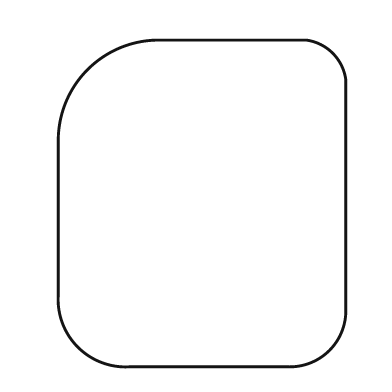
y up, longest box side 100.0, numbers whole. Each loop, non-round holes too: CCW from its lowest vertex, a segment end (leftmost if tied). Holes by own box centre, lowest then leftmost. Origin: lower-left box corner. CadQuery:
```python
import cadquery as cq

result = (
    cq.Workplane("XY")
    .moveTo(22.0, 0.0)
    .lineTo(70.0, 0.0)
    .threePointArc((83.0, 5.0), (88.0, 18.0))
    .lineTo(88.0, 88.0)
    .threePointArc((84.0, 96.0), (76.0, 100.0))
    .lineTo(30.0, 100.0)
    .threePointArc((9.0, 91.0), (0.0, 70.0))
    .lineTo(0.0, 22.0)
    .threePointArc((6.0, 6.0), (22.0, 0.0))
    .close()
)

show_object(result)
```